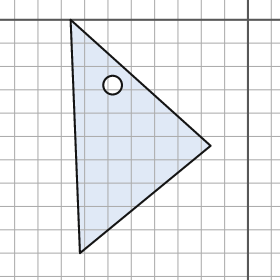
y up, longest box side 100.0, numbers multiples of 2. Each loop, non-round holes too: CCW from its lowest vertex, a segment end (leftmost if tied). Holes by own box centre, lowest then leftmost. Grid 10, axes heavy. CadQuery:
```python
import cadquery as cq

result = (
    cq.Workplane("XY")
    .moveTo(-72.0, -100.0)
    .lineTo(-16.0, -54.0)
    .lineTo(-76.0, 0.0)
    .close()
    .moveTo(-58.0, -28.0)
    .circle(4.0)
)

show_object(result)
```